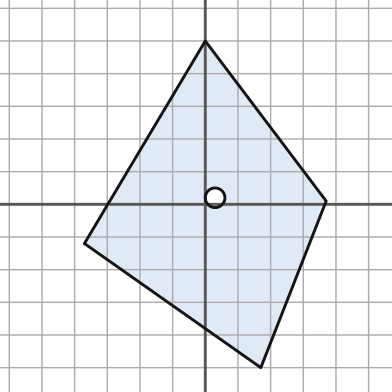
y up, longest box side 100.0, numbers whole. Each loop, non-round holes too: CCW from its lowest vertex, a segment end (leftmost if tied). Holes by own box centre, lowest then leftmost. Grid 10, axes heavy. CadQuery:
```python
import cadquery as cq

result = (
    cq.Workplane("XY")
    .moveTo(17.0, -50.0)
    .lineTo(37.0, 1.0)
    .lineTo(0.0, 50.0)
    .lineTo(-37.0, -12.0)
    .close()
    .moveTo(3.0, 2.0)
    .circle(3.0)
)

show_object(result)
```